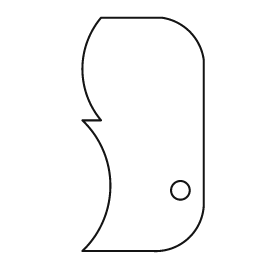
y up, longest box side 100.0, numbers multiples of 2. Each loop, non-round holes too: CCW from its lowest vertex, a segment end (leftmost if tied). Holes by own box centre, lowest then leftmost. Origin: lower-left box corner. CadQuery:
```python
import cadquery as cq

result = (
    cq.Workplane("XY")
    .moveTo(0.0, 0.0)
    .lineTo(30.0, 0.0)
    .threePointArc((46.0, 6.0), (52.0, 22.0))
    .lineTo(52.0, 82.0)
    .threePointArc((46.0, 94.0), (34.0, 100.0))
    .lineTo(8.0, 100.0)
    .threePointArc((0.0, 78.0), (8.0, 56.0))
    .lineTo(0.0, 56.0)
    .threePointArc((12.0, 28.0), (0.0, 0.0))
    .close()
    .moveTo(42.0, 26.0)
    .circle(4.0)
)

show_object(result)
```